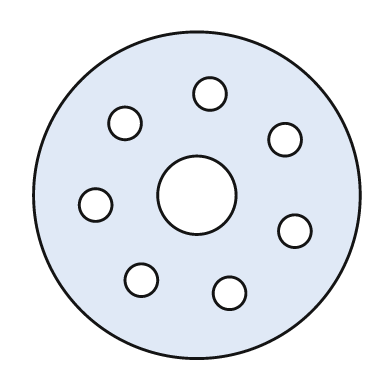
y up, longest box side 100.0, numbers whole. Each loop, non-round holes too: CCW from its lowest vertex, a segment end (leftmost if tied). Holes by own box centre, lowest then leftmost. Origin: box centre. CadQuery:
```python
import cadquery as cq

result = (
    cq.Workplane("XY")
    .moveTo(0.0, 0.0)
    .circle(50.0)
    .moveTo(10.0, -30.0)
    .circle(5.0)
    .moveTo(-17.0, -26.0)
    .circle(5.0)
    .moveTo(30.0, -11.0)
    .circle(5.0)
    .moveTo(-31.0, -3.0)
    .circle(5.0)
    .moveTo(0.0, 0.0)
    .circle(12.0)
    .moveTo(27.0, 17.0)
    .circle(5.0)
    .moveTo(-22.0, 22.0)
    .circle(5.0)
    .moveTo(4.0, 31.0)
    .circle(5.0)
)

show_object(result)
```